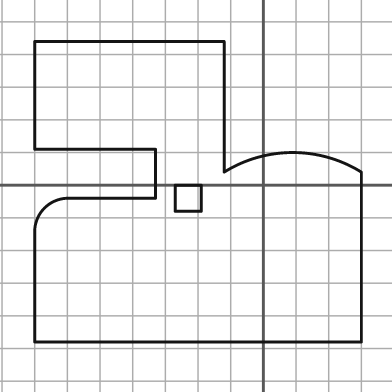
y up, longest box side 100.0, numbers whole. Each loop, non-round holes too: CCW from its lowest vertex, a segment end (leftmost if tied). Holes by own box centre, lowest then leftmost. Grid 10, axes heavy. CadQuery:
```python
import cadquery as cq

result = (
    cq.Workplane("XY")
    .moveTo(-70.0, -48.0)
    .lineTo(30.0, -48.0)
    .lineTo(30.0, 4.0)
    .threePointArc((9.0, 10.0), (-12.0, 4.0))
    .lineTo(-12.0, 44.0)
    .lineTo(-70.0, 44.0)
    .lineTo(-70.0, 11.0)
    .lineTo(-33.0, 11.0)
    .lineTo(-33.0, -4.0)
    .lineTo(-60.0, -4.0)
    .threePointArc((-67.0, -7.0), (-70.0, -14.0))
    .close()
    .moveTo(-27.0, -8.0)
    .lineTo(-19.0, -8.0)
    .lineTo(-19.0, 0.0)
    .lineTo(-27.0, 0.0)
    .close()
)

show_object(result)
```